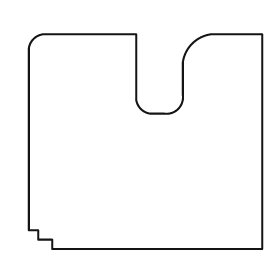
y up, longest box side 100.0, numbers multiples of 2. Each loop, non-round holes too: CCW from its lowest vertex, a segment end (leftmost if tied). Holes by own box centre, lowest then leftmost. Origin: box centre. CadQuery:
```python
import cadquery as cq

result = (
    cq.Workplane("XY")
    .moveTo(-40.0, -46.0)
    .lineTo(50.0, -46.0)
    .lineTo(50.0, 46.0)
    .lineTo(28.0, 46.0)
    .threePointArc((20.0, 42.0), (16.0, 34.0))
    .lineTo(16.0, 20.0)
    .threePointArc((14.0, 14.0), (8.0, 12.0))
    .lineTo(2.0, 12.0)
    .threePointArc((-2.0, 14.0), (-4.0, 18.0))
    .lineTo(-4.0, 46.0)
    .lineTo(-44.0, 46.0)
    .threePointArc((-48.0, 44.0), (-50.0, 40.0))
    .lineTo(-50.0, -38.0)
    .lineTo(-46.0, -38.0)
    .lineTo(-46.0, -42.0)
    .lineTo(-40.0, -42.0)
    .close()
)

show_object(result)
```